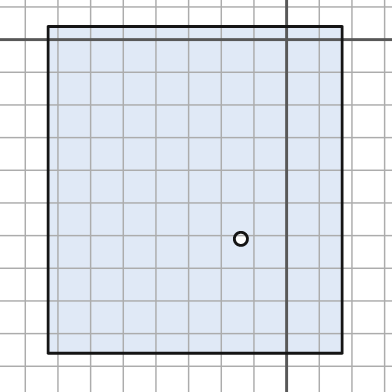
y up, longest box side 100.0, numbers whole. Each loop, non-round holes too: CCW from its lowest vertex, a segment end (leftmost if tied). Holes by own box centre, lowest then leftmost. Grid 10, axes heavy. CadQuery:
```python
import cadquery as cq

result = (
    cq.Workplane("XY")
    .moveTo(-73.0, -96.0)
    .lineTo(17.0, -96.0)
    .lineTo(17.0, 4.0)
    .lineTo(-73.0, 4.0)
    .close()
    .moveTo(-14.0, -61.0)
    .circle(2.0)
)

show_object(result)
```